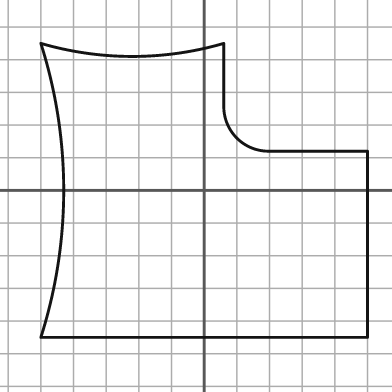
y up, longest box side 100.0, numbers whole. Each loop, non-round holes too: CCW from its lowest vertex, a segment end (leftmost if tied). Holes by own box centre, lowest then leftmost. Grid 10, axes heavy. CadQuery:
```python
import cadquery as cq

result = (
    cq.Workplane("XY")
    .moveTo(-50.0, -45.0)
    .lineTo(50.0, -45.0)
    .lineTo(50.0, 12.0)
    .lineTo(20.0, 12.0)
    .threePointArc((10.0, 16.0), (6.0, 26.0))
    .lineTo(6.0, 45.0)
    .threePointArc((-22.0, 41.0), (-50.0, 45.0))
    .threePointArc((-43.0, 0.0), (-50.0, -45.0))
    .close()
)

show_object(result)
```